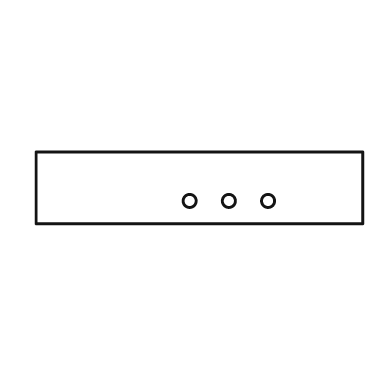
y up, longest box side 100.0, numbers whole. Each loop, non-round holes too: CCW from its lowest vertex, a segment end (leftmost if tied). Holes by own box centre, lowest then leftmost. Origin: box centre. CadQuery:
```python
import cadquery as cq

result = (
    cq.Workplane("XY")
    .moveTo(-50.0, -11.0)
    .lineTo(50.0, -11.0)
    .lineTo(50.0, 11.0)
    .lineTo(-50.0, 11.0)
    .close()
    .moveTo(-3.0, -4.0)
    .circle(2.0)
    .moveTo(9.0, -4.0)
    .circle(2.0)
    .moveTo(21.0, -4.0)
    .circle(2.0)
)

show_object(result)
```